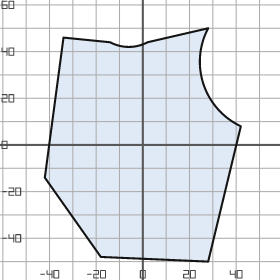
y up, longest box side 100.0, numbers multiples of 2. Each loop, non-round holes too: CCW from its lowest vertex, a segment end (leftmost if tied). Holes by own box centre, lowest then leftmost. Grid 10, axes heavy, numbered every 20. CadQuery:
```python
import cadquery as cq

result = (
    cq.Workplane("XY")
    .moveTo(28.0, -50.0)
    .lineTo(42.0, 8.0)
    .threePointArc((26.0, 26.0), (28.0, 50.0))
    .lineTo(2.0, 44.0)
    .threePointArc((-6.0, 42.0), (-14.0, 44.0))
    .lineTo(-34.0, 46.0)
    .lineTo(-42.0, -14.0)
    .lineTo(-18.0, -48.0)
    .close()
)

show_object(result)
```